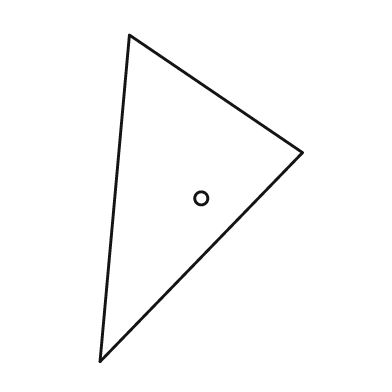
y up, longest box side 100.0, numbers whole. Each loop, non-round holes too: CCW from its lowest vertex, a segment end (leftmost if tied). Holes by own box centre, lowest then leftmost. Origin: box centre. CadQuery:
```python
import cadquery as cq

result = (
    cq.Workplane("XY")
    .moveTo(-31.0, -50.0)
    .lineTo(31.0, 14.0)
    .lineTo(-22.0, 50.0)
    .close()
    .moveTo(0.0, 0.0)
    .circle(2.0)
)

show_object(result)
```